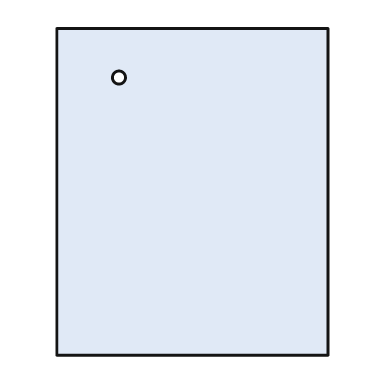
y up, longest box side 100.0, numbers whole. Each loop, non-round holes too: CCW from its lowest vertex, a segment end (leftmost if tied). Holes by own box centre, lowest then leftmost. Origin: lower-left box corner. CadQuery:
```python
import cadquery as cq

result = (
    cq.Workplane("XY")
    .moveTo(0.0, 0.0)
    .lineTo(83.0, 0.0)
    .lineTo(83.0, 100.0)
    .lineTo(0.0, 100.0)
    .close()
    .moveTo(19.0, 85.0)
    .circle(2.0)
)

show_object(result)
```